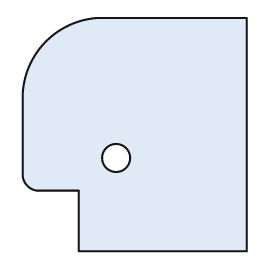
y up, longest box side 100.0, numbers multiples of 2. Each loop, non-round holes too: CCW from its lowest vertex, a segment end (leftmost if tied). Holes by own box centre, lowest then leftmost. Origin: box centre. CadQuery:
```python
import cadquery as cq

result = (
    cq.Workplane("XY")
    .moveTo(-24.0, -50.0)
    .lineTo(48.0, -50.0)
    .lineTo(48.0, 50.0)
    .lineTo(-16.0, 50.0)
    .threePointArc((-38.0, 40.0), (-48.0, 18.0))
    .lineTo(-48.0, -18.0)
    .threePointArc((-46.0, -22.0), (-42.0, -24.0))
    .lineTo(-24.0, -24.0)
    .close()
    .moveTo(-8.0, -10.0)
    .circle(6.0)
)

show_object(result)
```